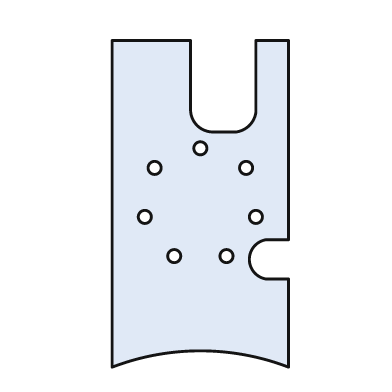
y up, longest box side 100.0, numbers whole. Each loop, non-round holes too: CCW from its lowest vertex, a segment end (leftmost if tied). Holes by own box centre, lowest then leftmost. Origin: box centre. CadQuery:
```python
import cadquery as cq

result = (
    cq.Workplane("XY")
    .moveTo(-27.0, -50.0)
    .threePointArc((0.0, -45.0), (27.0, -50.0))
    .lineTo(27.0, -23.0)
    .lineTo(20.0, -23.0)
    .threePointArc((15.0, -17.0), (20.0, -11.0))
    .lineTo(27.0, -11.0)
    .lineTo(27.0, 50.0)
    .lineTo(17.0, 50.0)
    .lineTo(17.0, 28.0)
    .threePointArc((15.0, 24.0), (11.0, 22.0))
    .lineTo(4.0, 22.0)
    .threePointArc((-1.0, 24.0), (-3.0, 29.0))
    .lineTo(-3.0, 50.0)
    .lineTo(-27.0, 50.0)
    .close()
    .moveTo(-8.0, -16.0)
    .circle(2.0)
    .moveTo(8.0, -16.0)
    .circle(2.0)
    .moveTo(-17.0, -4.0)
    .circle(2.0)
    .moveTo(17.0, -4.0)
    .circle(2.0)
    .moveTo(-14.0, 11.0)
    .circle(2.0)
    .moveTo(14.0, 11.0)
    .circle(2.0)
    .moveTo(0.0, 17.0)
    .circle(2.0)
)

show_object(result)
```